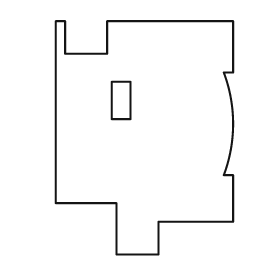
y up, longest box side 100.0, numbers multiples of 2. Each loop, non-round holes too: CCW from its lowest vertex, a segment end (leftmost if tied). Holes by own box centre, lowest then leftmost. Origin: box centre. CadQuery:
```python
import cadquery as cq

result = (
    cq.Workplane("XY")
    .moveTo(-12.0, -50.0)
    .lineTo(6.0, -50.0)
    .lineTo(6.0, -36.0)
    .lineTo(38.0, -36.0)
    .lineTo(38.0, -16.0)
    .lineTo(34.0, -16.0)
    .threePointArc((38.0, 6.0), (34.0, 28.0))
    .lineTo(38.0, 28.0)
    .lineTo(38.0, 50.0)
    .lineTo(-16.0, 50.0)
    .lineTo(-16.0, 36.0)
    .lineTo(-34.0, 36.0)
    .lineTo(-34.0, 50.0)
    .lineTo(-38.0, 50.0)
    .lineTo(-38.0, -28.0)
    .lineTo(-12.0, -28.0)
    .close()
    .moveTo(-14.0, 8.0)
    .lineTo(-6.0, 8.0)
    .lineTo(-6.0, 24.0)
    .lineTo(-14.0, 24.0)
    .close()
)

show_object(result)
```